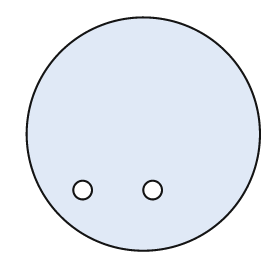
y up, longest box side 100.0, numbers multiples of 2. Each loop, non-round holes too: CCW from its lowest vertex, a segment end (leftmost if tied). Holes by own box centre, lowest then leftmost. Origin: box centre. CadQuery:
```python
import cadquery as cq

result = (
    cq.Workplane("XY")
    .moveTo(0.0, 0.0)
    .circle(50.0)
    .moveTo(-26.0, -24.0)
    .circle(4.0)
    .moveTo(4.0, -24.0)
    .circle(4.0)
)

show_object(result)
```